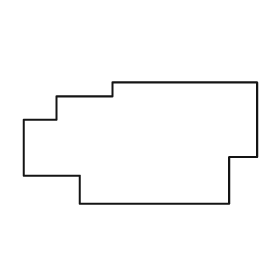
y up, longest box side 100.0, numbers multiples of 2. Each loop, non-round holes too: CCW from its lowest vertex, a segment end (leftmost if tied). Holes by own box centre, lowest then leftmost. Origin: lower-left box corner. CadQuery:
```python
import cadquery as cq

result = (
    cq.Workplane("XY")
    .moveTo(24.0, 0.0)
    .lineTo(88.0, 0.0)
    .lineTo(88.0, 20.0)
    .lineTo(100.0, 20.0)
    .lineTo(100.0, 52.0)
    .lineTo(38.0, 52.0)
    .lineTo(38.0, 46.0)
    .lineTo(14.0, 46.0)
    .lineTo(14.0, 36.0)
    .lineTo(0.0, 36.0)
    .lineTo(0.0, 12.0)
    .lineTo(24.0, 12.0)
    .close()
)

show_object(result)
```